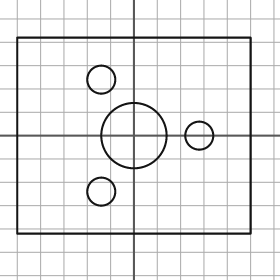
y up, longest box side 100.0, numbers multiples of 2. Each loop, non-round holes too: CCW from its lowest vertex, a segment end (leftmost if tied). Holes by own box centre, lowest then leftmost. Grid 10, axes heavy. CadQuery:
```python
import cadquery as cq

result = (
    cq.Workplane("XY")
    .moveTo(-50.0, -42.0)
    .lineTo(50.0, -42.0)
    .lineTo(50.0, 42.0)
    .lineTo(-50.0, 42.0)
    .close()
    .moveTo(-14.0, -24.0)
    .circle(6.0)
    .moveTo(0.0, 0.0)
    .circle(14.0)
    .moveTo(28.0, 0.0)
    .circle(6.0)
    .moveTo(-14.0, 24.0)
    .circle(6.0)
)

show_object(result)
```